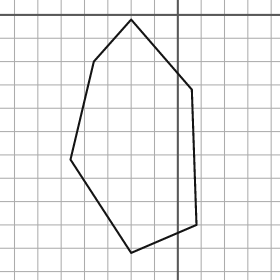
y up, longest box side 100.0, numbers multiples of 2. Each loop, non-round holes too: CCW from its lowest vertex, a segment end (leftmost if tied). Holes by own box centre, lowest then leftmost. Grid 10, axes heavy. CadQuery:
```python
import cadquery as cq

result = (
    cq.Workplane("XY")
    .moveTo(-20.0, -102.0)
    .lineTo(8.0, -90.0)
    .lineTo(6.0, -32.0)
    .lineTo(-20.0, -2.0)
    .lineTo(-36.0, -20.0)
    .lineTo(-46.0, -62.0)
    .close()
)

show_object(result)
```